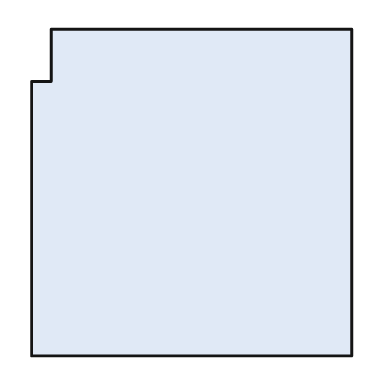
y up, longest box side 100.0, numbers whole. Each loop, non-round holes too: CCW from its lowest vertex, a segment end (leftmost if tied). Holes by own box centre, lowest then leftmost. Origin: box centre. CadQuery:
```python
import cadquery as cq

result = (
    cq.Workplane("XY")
    .moveTo(-49.0, -50.0)
    .lineTo(49.0, -50.0)
    .lineTo(49.0, 50.0)
    .lineTo(-43.0, 50.0)
    .lineTo(-43.0, 34.0)
    .lineTo(-49.0, 34.0)
    .close()
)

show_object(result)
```